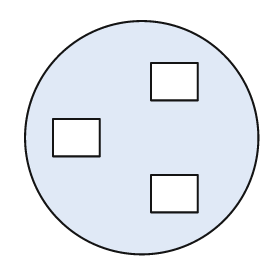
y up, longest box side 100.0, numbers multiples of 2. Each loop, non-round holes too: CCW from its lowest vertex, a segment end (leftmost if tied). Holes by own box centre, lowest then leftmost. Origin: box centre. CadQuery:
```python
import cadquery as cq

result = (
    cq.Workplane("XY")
    .moveTo(0.0, 0.0)
    .circle(50.0)
    .moveTo(4.0, -32.0)
    .lineTo(24.0, -32.0)
    .lineTo(24.0, -16.0)
    .lineTo(4.0, -16.0)
    .close()
    .moveTo(-38.0, -8.0)
    .lineTo(-18.0, -8.0)
    .lineTo(-18.0, 8.0)
    .lineTo(-38.0, 8.0)
    .close()
    .moveTo(4.0, 16.0)
    .lineTo(24.0, 16.0)
    .lineTo(24.0, 32.0)
    .lineTo(4.0, 32.0)
    .close()
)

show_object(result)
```